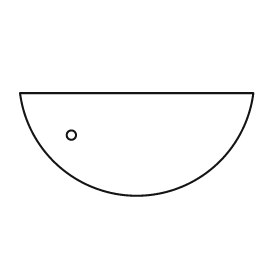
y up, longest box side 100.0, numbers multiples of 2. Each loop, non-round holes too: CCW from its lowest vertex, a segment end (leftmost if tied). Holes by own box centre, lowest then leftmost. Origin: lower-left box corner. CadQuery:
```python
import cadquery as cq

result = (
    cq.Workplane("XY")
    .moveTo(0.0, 44.0)
    .threePointArc((50.0, 0.0), (100.0, 44.0))
    .close()
    .moveTo(22.0, 26.0)
    .circle(2.0)
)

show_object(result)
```